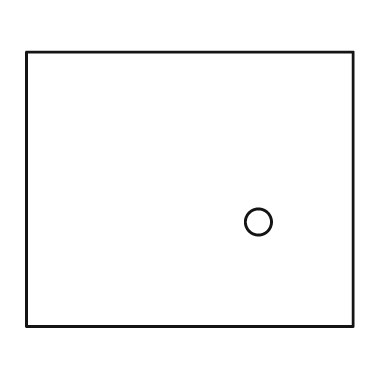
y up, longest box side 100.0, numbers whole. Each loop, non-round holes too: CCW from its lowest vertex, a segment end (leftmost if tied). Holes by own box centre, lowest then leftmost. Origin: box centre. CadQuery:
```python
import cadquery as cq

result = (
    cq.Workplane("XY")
    .moveTo(-50.0, -42.0)
    .lineTo(50.0, -42.0)
    .lineTo(50.0, 42.0)
    .lineTo(-50.0, 42.0)
    .close()
    .moveTo(21.0, -10.0)
    .circle(4.0)
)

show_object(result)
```